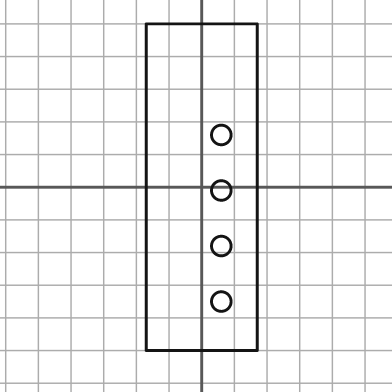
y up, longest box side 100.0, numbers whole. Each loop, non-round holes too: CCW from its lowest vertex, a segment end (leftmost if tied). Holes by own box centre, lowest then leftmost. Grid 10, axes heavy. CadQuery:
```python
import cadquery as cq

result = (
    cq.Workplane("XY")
    .moveTo(-17.0, -50.0)
    .lineTo(17.0, -50.0)
    .lineTo(17.0, 50.0)
    .lineTo(-17.0, 50.0)
    .close()
    .moveTo(6.0, -35.0)
    .circle(3.0)
    .moveTo(6.0, -18.0)
    .circle(3.0)
    .moveTo(6.0, -1.0)
    .circle(3.0)
    .moveTo(6.0, 16.0)
    .circle(3.0)
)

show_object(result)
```